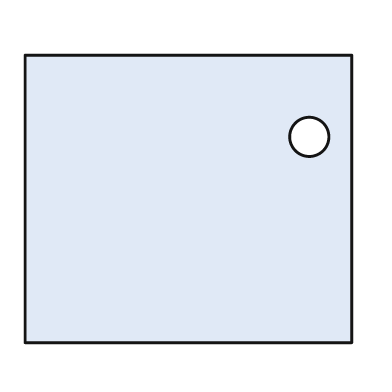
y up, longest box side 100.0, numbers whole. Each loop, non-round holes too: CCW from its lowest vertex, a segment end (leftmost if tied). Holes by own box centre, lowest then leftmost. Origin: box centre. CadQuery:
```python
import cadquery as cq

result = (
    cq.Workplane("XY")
    .moveTo(-50.0, -44.0)
    .lineTo(50.0, -44.0)
    .lineTo(50.0, 44.0)
    .lineTo(-50.0, 44.0)
    .close()
    .moveTo(37.0, 19.0)
    .circle(6.0)
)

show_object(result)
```